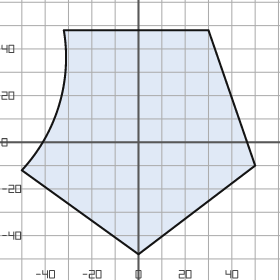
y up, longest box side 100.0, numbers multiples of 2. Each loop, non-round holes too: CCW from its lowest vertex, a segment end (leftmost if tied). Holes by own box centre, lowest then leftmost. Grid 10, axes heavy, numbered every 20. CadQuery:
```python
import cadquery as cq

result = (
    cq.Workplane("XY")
    .moveTo(0.0, -48.0)
    .lineTo(50.0, -10.0)
    .lineTo(30.0, 48.0)
    .lineTo(-32.0, 48.0)
    .threePointArc((-34.0, 16.0), (-50.0, -12.0))
    .close()
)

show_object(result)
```